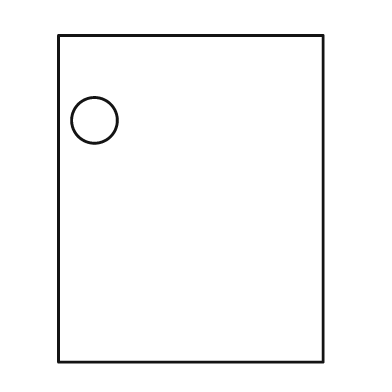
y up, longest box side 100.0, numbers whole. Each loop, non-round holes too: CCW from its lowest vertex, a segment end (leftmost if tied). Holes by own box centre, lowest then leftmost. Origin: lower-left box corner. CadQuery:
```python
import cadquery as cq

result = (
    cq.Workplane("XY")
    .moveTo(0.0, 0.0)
    .lineTo(81.0, 0.0)
    .lineTo(81.0, 100.0)
    .lineTo(0.0, 100.0)
    .close()
    .moveTo(11.0, 74.0)
    .circle(7.0)
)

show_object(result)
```